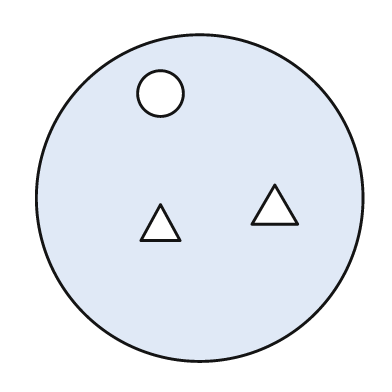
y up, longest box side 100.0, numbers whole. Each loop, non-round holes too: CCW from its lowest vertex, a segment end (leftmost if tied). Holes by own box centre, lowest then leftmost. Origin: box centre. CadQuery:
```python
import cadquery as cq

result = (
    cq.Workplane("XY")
    .moveTo(0.0, 0.0)
    .circle(50.0)
    .moveTo(-18.0, -13.0)
    .lineTo(-6.0, -13.0)
    .lineTo(-12.0, -2.0)
    .close()
    .moveTo(16.0, -8.0)
    .lineTo(30.0, -8.0)
    .lineTo(23.0, 4.0)
    .close()
    .moveTo(-12.0, 32.0)
    .circle(7.0)
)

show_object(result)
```